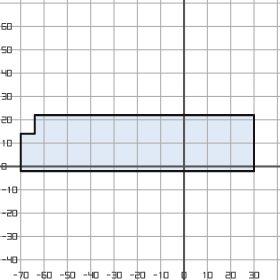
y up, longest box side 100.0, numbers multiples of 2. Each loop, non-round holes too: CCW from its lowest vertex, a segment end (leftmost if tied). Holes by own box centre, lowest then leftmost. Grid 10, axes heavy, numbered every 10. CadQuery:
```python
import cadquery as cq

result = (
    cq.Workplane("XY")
    .moveTo(-70.0, -2.0)
    .lineTo(30.0, -2.0)
    .lineTo(30.0, 22.0)
    .lineTo(-64.0, 22.0)
    .lineTo(-64.0, 14.0)
    .lineTo(-70.0, 14.0)
    .close()
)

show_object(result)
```